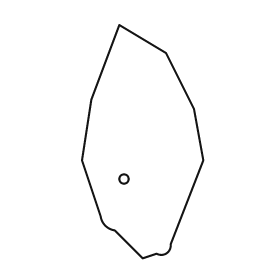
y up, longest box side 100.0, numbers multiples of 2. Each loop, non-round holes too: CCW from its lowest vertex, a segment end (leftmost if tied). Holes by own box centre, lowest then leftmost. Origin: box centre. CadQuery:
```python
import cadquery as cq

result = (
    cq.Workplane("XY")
    .moveTo(0.0, -50.0)
    .lineTo(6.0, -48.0)
    .threePointArc((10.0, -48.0), (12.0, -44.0))
    .lineTo(26.0, -8.0)
    .lineTo(22.0, 14.0)
    .lineTo(10.0, 38.0)
    .lineTo(-10.0, 50.0)
    .lineTo(-22.0, 18.0)
    .lineTo(-26.0, -8.0)
    .lineTo(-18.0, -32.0)
    .threePointArc((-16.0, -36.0), (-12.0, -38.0))
    .close()
    .moveTo(-8.0, -16.0)
    .circle(2.0)
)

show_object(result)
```